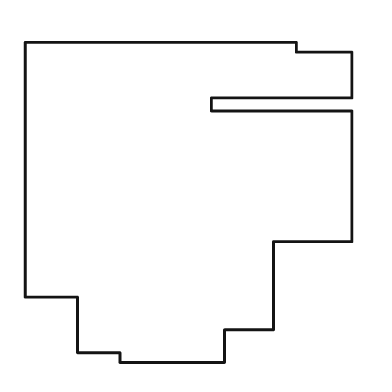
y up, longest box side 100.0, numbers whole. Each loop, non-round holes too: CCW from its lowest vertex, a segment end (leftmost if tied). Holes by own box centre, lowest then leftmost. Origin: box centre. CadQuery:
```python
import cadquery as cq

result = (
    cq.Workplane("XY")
    .moveTo(-21.0, -49.0)
    .lineTo(11.0, -49.0)
    .lineTo(11.0, -39.0)
    .lineTo(26.0, -39.0)
    .lineTo(26.0, -12.0)
    .lineTo(50.0, -12.0)
    .lineTo(50.0, 28.0)
    .lineTo(7.0, 28.0)
    .lineTo(7.0, 32.0)
    .lineTo(50.0, 32.0)
    .lineTo(50.0, 46.0)
    .lineTo(33.0, 46.0)
    .lineTo(33.0, 49.0)
    .lineTo(-50.0, 49.0)
    .lineTo(-50.0, -29.0)
    .lineTo(-34.0, -29.0)
    .lineTo(-34.0, -46.0)
    .lineTo(-21.0, -46.0)
    .close()
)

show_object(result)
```